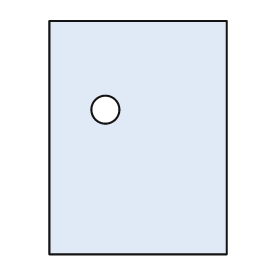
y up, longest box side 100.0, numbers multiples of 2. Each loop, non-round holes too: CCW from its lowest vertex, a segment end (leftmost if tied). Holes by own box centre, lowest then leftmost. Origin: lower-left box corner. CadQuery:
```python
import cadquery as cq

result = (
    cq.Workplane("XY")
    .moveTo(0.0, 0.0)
    .lineTo(76.0, 0.0)
    .lineTo(76.0, 100.0)
    .lineTo(0.0, 100.0)
    .close()
    .moveTo(24.0, 62.0)
    .circle(6.0)
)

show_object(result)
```